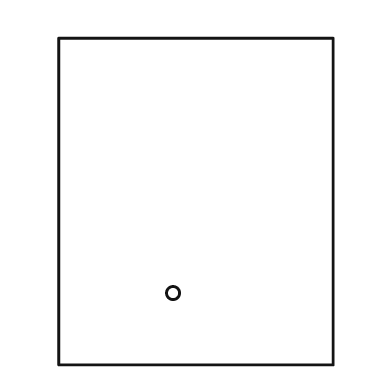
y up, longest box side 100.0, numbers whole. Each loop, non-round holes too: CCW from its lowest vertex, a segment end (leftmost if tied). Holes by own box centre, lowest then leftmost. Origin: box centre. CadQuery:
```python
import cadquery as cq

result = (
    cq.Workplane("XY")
    .moveTo(-42.0, -50.0)
    .lineTo(42.0, -50.0)
    .lineTo(42.0, 50.0)
    .lineTo(-42.0, 50.0)
    .close()
    .moveTo(-7.0, -28.0)
    .circle(2.0)
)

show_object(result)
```